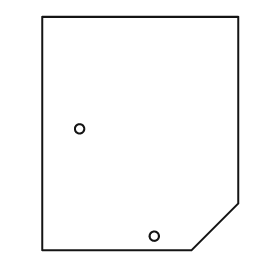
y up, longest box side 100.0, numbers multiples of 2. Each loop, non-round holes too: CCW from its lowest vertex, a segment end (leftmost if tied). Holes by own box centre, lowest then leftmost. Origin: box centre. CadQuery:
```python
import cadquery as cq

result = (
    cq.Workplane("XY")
    .moveTo(-42.0, -50.0)
    .lineTo(22.0, -50.0)
    .lineTo(42.0, -30.0)
    .lineTo(42.0, 50.0)
    .lineTo(-42.0, 50.0)
    .close()
    .moveTo(6.0, -44.0)
    .circle(2.0)
    .moveTo(-26.0, 2.0)
    .circle(2.0)
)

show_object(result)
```